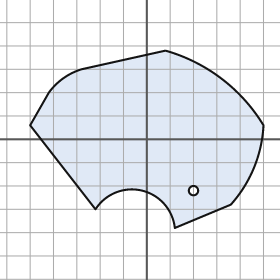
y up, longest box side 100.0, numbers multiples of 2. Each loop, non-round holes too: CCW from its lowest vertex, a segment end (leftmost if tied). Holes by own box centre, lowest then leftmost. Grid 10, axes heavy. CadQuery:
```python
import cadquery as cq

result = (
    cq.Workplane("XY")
    .moveTo(12.0, -38.0)
    .lineTo(36.0, -28.0)
    .threePointArc((46.0, -12.0), (50.0, 6.0))
    .threePointArc((32.0, 26.0), (8.0, 38.0))
    .lineTo(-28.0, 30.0)
    .threePointArc((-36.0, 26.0), (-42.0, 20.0))
    .lineTo(-50.0, 6.0)
    .lineTo(-22.0, -30.0)
    .threePointArc((-2.0, -22.0), (12.0, -38.0))
    .close()
    .moveTo(20.0, -22.0)
    .circle(2.0)
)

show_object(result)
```